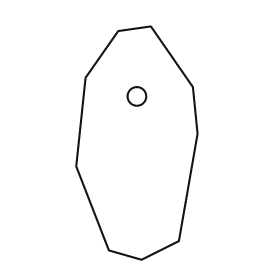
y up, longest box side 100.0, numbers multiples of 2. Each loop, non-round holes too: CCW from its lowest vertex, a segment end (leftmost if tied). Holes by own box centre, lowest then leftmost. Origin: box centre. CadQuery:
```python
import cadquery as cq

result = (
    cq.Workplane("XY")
    .moveTo(2.0, -50.0)
    .lineTo(18.0, -42.0)
    .lineTo(26.0, 4.0)
    .lineTo(24.0, 24.0)
    .lineTo(6.0, 50.0)
    .lineTo(-8.0, 48.0)
    .lineTo(-22.0, 28.0)
    .lineTo(-26.0, -10.0)
    .lineTo(-12.0, -46.0)
    .close()
    .moveTo(0.0, 20.0)
    .circle(4.0)
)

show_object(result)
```